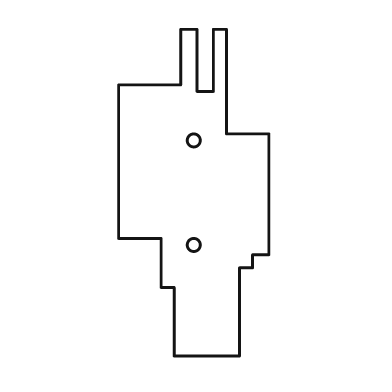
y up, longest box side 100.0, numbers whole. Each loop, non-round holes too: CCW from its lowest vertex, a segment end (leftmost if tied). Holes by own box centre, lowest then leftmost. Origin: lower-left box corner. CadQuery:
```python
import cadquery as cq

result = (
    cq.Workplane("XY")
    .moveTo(17.0, 0.0)
    .lineTo(37.0, 0.0)
    .lineTo(37.0, 27.0)
    .lineTo(41.0, 27.0)
    .lineTo(41.0, 31.0)
    .lineTo(46.0, 31.0)
    .lineTo(46.0, 68.0)
    .lineTo(33.0, 68.0)
    .lineTo(33.0, 100.0)
    .lineTo(29.0, 100.0)
    .lineTo(29.0, 81.0)
    .lineTo(24.0, 81.0)
    .lineTo(24.0, 100.0)
    .lineTo(19.0, 100.0)
    .lineTo(19.0, 83.0)
    .lineTo(0.0, 83.0)
    .lineTo(0.0, 36.0)
    .lineTo(13.0, 36.0)
    .lineTo(13.0, 21.0)
    .lineTo(17.0, 21.0)
    .close()
    .moveTo(23.0, 34.0)
    .circle(2.0)
    .moveTo(23.0, 66.0)
    .circle(2.0)
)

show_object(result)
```